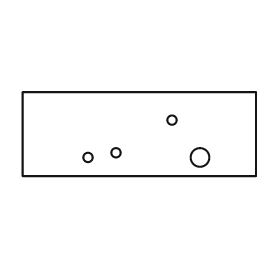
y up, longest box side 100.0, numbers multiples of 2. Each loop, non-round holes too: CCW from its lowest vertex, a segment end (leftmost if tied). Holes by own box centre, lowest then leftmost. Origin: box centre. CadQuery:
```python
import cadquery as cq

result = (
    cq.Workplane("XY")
    .moveTo(-50.0, -18.0)
    .lineTo(50.0, -18.0)
    .lineTo(50.0, 18.0)
    .lineTo(-50.0, 18.0)
    .close()
    .moveTo(-22.0, -10.0)
    .circle(2.0)
    .moveTo(26.0, -10.0)
    .circle(4.0)
    .moveTo(-10.0, -8.0)
    .circle(2.0)
    .moveTo(14.0, 6.0)
    .circle(2.0)
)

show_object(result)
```